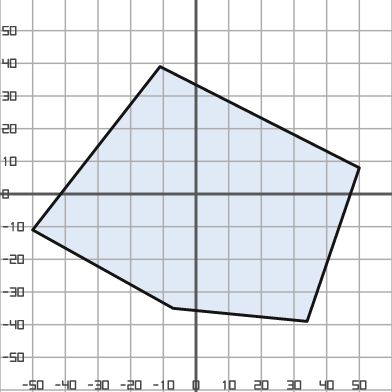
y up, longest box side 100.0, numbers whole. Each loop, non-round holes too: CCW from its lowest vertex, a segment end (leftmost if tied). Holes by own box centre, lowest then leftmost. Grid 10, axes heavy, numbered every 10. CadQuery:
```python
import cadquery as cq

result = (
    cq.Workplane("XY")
    .moveTo(34.0, -39.0)
    .lineTo(50.0, 8.0)
    .lineTo(-11.0, 39.0)
    .lineTo(-50.0, -11.0)
    .lineTo(-7.0, -35.0)
    .close()
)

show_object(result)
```